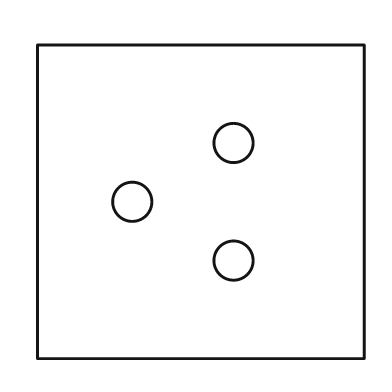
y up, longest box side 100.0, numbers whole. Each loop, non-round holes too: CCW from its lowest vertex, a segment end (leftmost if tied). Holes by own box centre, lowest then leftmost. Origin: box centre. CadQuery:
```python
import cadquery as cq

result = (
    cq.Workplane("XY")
    .moveTo(-50.0, -48.0)
    .lineTo(50.0, -48.0)
    .lineTo(50.0, 48.0)
    .lineTo(-50.0, 48.0)
    .close()
    .moveTo(10.0, -18.0)
    .circle(6.0)
    .moveTo(-21.0, 0.0)
    .circle(6.0)
    .moveTo(10.0, 18.0)
    .circle(6.0)
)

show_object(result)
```